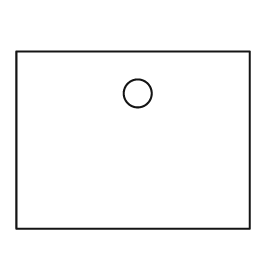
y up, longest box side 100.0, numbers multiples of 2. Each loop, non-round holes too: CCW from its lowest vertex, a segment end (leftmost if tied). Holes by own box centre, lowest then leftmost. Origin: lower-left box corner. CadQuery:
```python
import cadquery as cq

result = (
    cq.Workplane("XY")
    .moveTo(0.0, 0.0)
    .lineTo(100.0, 0.0)
    .lineTo(100.0, 76.0)
    .lineTo(0.0, 76.0)
    .close()
    .moveTo(52.0, 58.0)
    .circle(6.0)
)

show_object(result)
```